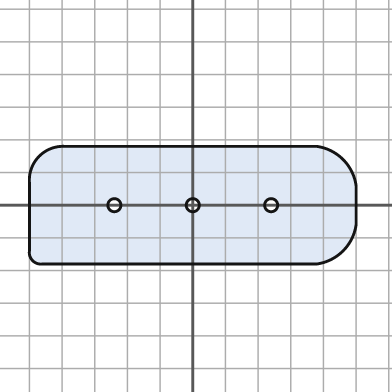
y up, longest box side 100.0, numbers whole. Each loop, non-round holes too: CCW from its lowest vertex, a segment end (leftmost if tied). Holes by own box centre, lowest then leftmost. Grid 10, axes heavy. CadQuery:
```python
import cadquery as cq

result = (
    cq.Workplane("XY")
    .moveTo(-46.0, -18.0)
    .lineTo(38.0, -18.0)
    .threePointArc((46.0, -14.0), (50.0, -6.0))
    .lineTo(50.0, 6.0)
    .threePointArc((46.0, 14.0), (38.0, 18.0))
    .lineTo(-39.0, 18.0)
    .threePointArc((-47.0, 15.0), (-50.0, 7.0))
    .lineTo(-50.0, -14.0)
    .threePointArc((-49.0, -17.0), (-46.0, -18.0))
    .close()
    .moveTo(-24.0, 0.0)
    .circle(2.0)
    .moveTo(0.0, 0.0)
    .circle(2.0)
    .moveTo(24.0, 0.0)
    .circle(2.0)
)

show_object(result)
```